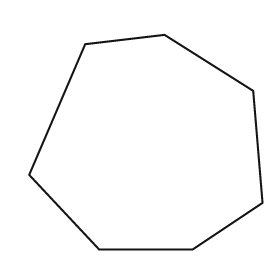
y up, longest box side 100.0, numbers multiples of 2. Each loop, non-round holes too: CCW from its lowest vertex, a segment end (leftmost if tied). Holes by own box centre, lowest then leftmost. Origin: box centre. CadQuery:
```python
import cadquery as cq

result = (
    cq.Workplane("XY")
    .moveTo(-20.0, -46.0)
    .lineTo(20.0, -46.0)
    .lineTo(50.0, -26.0)
    .lineTo(46.0, 22.0)
    .lineTo(8.0, 46.0)
    .lineTo(-26.0, 42.0)
    .lineTo(-50.0, -14.0)
    .close()
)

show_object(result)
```